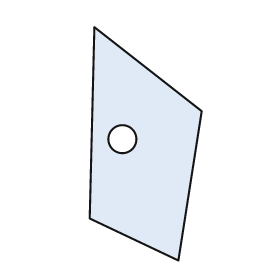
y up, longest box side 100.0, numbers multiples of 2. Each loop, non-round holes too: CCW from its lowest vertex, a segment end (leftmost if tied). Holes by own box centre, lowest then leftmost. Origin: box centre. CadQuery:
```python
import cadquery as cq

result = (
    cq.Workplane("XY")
    .moveTo(14.0, -50.0)
    .lineTo(24.0, 14.0)
    .lineTo(-22.0, 50.0)
    .lineTo(-24.0, -32.0)
    .close()
    .moveTo(-10.0, 2.0)
    .circle(6.0)
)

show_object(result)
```